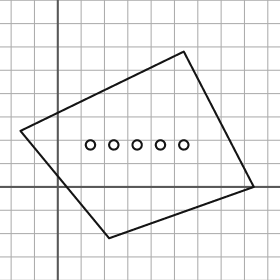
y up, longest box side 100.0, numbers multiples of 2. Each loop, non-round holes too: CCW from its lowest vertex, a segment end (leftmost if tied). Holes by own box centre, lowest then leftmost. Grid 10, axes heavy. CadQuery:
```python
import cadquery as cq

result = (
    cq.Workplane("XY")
    .moveTo(22.0, -22.0)
    .lineTo(84.0, 0.0)
    .lineTo(54.0, 58.0)
    .lineTo(-16.0, 24.0)
    .close()
    .moveTo(14.0, 18.0)
    .circle(2.0)
    .moveTo(24.0, 18.0)
    .circle(2.0)
    .moveTo(34.0, 18.0)
    .circle(2.0)
    .moveTo(44.0, 18.0)
    .circle(2.0)
    .moveTo(54.0, 18.0)
    .circle(2.0)
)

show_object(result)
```